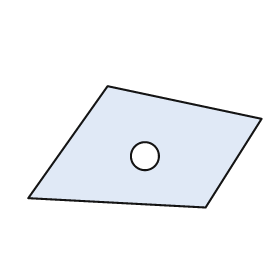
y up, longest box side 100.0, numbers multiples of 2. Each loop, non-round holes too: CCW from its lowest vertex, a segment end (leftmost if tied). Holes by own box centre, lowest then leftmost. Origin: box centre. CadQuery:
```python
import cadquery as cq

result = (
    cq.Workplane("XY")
    .moveTo(26.0, -26.0)
    .lineTo(50.0, 12.0)
    .lineTo(-16.0, 26.0)
    .lineTo(-50.0, -22.0)
    .close()
    .moveTo(0.0, -4.0)
    .circle(6.0)
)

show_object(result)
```